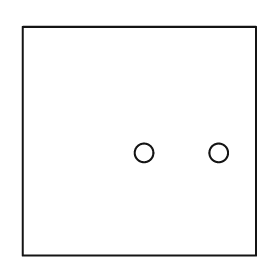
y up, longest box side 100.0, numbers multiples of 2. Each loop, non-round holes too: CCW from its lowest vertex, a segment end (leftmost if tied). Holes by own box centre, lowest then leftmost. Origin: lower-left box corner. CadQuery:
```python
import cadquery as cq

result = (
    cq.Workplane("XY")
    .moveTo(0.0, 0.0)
    .lineTo(100.0, 0.0)
    .lineTo(100.0, 98.0)
    .lineTo(0.0, 98.0)
    .close()
    .moveTo(52.0, 44.0)
    .circle(4.0)
    .moveTo(84.0, 44.0)
    .circle(4.0)
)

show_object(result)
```